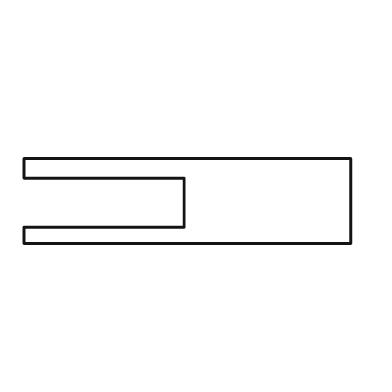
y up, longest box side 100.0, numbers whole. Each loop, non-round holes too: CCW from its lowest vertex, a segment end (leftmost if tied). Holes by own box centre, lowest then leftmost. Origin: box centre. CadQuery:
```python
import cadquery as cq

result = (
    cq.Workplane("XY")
    .moveTo(-50.0, -13.0)
    .lineTo(50.0, -13.0)
    .lineTo(50.0, 13.0)
    .lineTo(-50.0, 13.0)
    .lineTo(-50.0, 7.0)
    .lineTo(-1.0, 7.0)
    .lineTo(-1.0, -8.0)
    .lineTo(-50.0, -8.0)
    .close()
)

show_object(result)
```